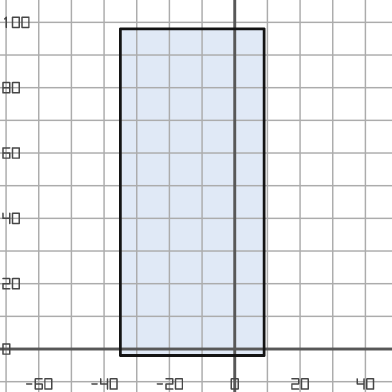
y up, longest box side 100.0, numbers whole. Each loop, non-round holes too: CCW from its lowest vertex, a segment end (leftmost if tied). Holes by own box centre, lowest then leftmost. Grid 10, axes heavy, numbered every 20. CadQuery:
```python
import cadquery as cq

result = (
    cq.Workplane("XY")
    .moveTo(-35.0, -2.0)
    .lineTo(9.0, -2.0)
    .lineTo(9.0, 98.0)
    .lineTo(-35.0, 98.0)
    .close()
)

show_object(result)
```